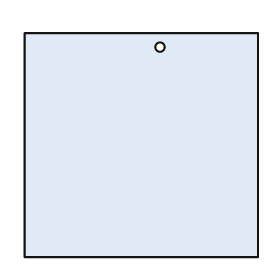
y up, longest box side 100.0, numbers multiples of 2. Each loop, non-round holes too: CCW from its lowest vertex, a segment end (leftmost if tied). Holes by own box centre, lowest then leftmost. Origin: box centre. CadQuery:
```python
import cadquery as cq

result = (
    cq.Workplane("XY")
    .moveTo(-50.0, -48.0)
    .lineTo(50.0, -48.0)
    .lineTo(50.0, 48.0)
    .lineTo(-50.0, 48.0)
    .close()
    .moveTo(8.0, 42.0)
    .circle(2.0)
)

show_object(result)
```